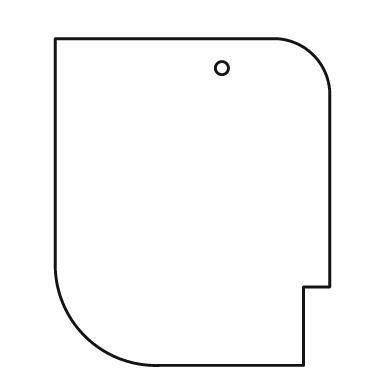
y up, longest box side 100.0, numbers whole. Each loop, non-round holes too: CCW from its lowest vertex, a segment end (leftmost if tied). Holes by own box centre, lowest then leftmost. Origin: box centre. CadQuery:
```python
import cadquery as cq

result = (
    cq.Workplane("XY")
    .moveTo(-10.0, -50.0)
    .lineTo(34.0, -50.0)
    .lineTo(34.0, -26.0)
    .lineTo(42.0, -26.0)
    .lineTo(42.0, 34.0)
    .threePointArc((37.0, 45.0), (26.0, 50.0))
    .lineTo(-42.0, 50.0)
    .lineTo(-42.0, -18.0)
    .threePointArc((-33.0, -41.0), (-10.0, -50.0))
    .close()
    .moveTo(9.0, 41.0)
    .circle(2.0)
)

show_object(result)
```